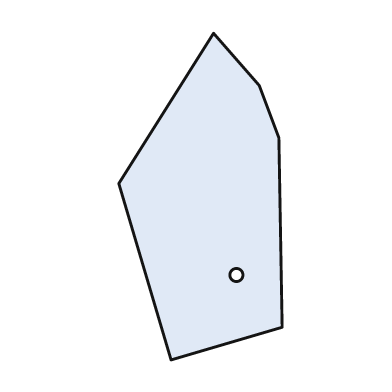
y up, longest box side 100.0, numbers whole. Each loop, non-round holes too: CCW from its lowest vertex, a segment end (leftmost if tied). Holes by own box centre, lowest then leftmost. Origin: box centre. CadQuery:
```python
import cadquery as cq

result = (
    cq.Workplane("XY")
    .moveTo(-9.0, -50.0)
    .lineTo(25.0, -40.0)
    .lineTo(24.0, 18.0)
    .lineTo(18.0, 34.0)
    .lineTo(4.0, 50.0)
    .lineTo(-25.0, 4.0)
    .close()
    .moveTo(11.0, -24.0)
    .circle(2.0)
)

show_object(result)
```